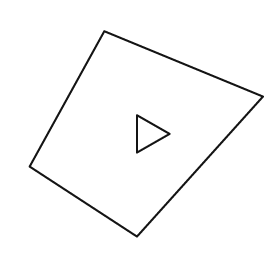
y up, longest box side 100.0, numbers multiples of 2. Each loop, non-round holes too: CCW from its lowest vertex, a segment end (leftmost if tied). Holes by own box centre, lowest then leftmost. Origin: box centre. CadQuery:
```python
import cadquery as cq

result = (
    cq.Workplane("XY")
    .moveTo(-4.0, -44.0)
    .lineTo(50.0, 16.0)
    .lineTo(-18.0, 44.0)
    .lineTo(-50.0, -14.0)
    .close()
    .moveTo(-4.0, -8.0)
    .lineTo(10.0, 0.0)
    .lineTo(-4.0, 8.0)
    .close()
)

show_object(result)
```